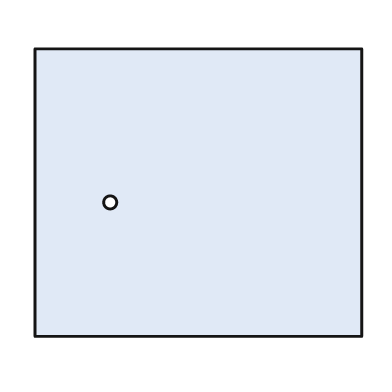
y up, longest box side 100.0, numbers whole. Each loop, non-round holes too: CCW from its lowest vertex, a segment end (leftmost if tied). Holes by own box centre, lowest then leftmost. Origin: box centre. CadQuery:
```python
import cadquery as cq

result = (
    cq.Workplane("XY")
    .moveTo(-50.0, -44.0)
    .lineTo(50.0, -44.0)
    .lineTo(50.0, 44.0)
    .lineTo(-50.0, 44.0)
    .close()
    .moveTo(-27.0, -3.0)
    .circle(2.0)
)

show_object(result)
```